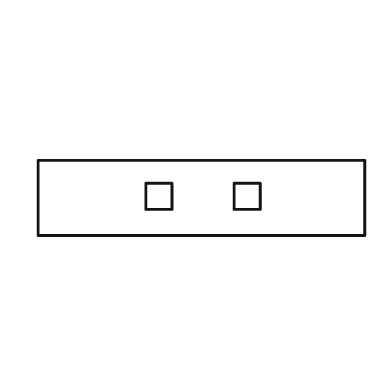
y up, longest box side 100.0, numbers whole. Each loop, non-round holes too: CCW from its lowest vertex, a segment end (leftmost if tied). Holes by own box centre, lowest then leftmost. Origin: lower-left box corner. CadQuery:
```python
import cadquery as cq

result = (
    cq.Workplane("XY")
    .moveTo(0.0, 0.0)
    .lineTo(100.0, 0.0)
    .lineTo(100.0, 23.0)
    .lineTo(0.0, 23.0)
    .close()
    .moveTo(33.0, 8.0)
    .lineTo(41.0, 8.0)
    .lineTo(41.0, 16.0)
    .lineTo(33.0, 16.0)
    .close()
    .moveTo(60.0, 8.0)
    .lineTo(68.0, 8.0)
    .lineTo(68.0, 16.0)
    .lineTo(60.0, 16.0)
    .close()
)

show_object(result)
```